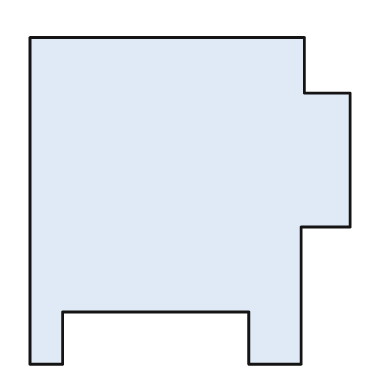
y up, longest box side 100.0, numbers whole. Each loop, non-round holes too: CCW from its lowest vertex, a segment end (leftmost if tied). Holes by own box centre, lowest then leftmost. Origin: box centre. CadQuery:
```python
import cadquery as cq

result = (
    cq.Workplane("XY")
    .moveTo(-49.0, -50.0)
    .lineTo(-39.0, -50.0)
    .lineTo(-39.0, -34.0)
    .lineTo(18.0, -34.0)
    .lineTo(18.0, -50.0)
    .lineTo(34.0, -50.0)
    .lineTo(34.0, -8.0)
    .lineTo(49.0, -8.0)
    .lineTo(49.0, 33.0)
    .lineTo(35.0, 33.0)
    .lineTo(35.0, 50.0)
    .lineTo(-49.0, 50.0)
    .close()
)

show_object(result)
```